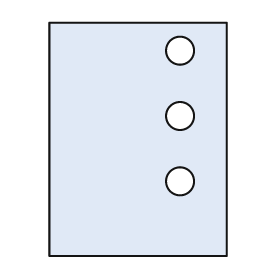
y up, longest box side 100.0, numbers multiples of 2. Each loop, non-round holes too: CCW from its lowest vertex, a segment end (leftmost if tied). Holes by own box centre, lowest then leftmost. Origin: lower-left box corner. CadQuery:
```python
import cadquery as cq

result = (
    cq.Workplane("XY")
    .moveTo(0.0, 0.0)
    .lineTo(76.0, 0.0)
    .lineTo(76.0, 100.0)
    .lineTo(0.0, 100.0)
    .close()
    .moveTo(56.0, 32.0)
    .circle(6.0)
    .moveTo(56.0, 60.0)
    .circle(6.0)
    .moveTo(56.0, 88.0)
    .circle(6.0)
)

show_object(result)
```